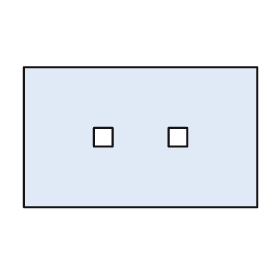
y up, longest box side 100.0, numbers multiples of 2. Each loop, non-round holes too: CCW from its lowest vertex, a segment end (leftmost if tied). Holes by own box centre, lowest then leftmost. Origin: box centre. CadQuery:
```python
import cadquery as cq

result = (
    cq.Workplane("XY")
    .moveTo(-50.0, -30.0)
    .lineTo(50.0, -30.0)
    .lineTo(50.0, 30.0)
    .lineTo(-50.0, 30.0)
    .close()
    .moveTo(-20.0, -4.0)
    .lineTo(-12.0, -4.0)
    .lineTo(-12.0, 4.0)
    .lineTo(-20.0, 4.0)
    .close()
    .moveTo(12.0, -4.0)
    .lineTo(20.0, -4.0)
    .lineTo(20.0, 4.0)
    .lineTo(12.0, 4.0)
    .close()
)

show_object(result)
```